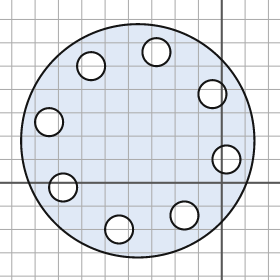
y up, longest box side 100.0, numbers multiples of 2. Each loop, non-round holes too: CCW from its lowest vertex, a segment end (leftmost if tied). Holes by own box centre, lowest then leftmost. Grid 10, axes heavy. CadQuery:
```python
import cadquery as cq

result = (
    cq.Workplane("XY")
    .moveTo(-36.0, 18.0)
    .circle(50.0)
    .moveTo(-44.0, -20.0)
    .circle(6.0)
    .moveTo(-16.0, -14.0)
    .circle(6.0)
    .moveTo(-68.0, -2.0)
    .circle(6.0)
    .moveTo(2.0, 10.0)
    .circle(6.0)
    .moveTo(-74.0, 26.0)
    .circle(6.0)
    .moveTo(-4.0, 38.0)
    .circle(6.0)
    .moveTo(-56.0, 50.0)
    .circle(6.0)
    .moveTo(-28.0, 56.0)
    .circle(6.0)
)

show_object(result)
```